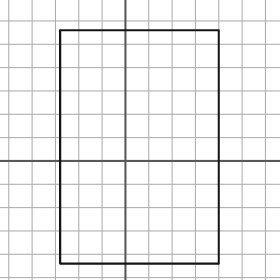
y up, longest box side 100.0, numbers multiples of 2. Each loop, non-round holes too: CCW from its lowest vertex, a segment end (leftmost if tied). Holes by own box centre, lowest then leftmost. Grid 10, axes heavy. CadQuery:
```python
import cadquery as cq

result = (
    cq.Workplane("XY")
    .moveTo(-28.0, -44.0)
    .lineTo(40.0, -44.0)
    .lineTo(40.0, 56.0)
    .lineTo(-28.0, 56.0)
    .close()
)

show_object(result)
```